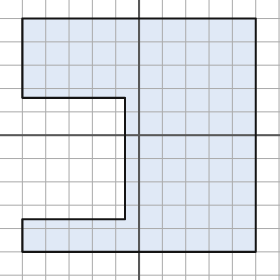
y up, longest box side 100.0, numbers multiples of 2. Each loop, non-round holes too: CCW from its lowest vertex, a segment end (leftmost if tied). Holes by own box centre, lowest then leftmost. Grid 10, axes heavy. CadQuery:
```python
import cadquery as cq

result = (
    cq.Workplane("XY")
    .moveTo(-50.0, -50.0)
    .lineTo(50.0, -50.0)
    .lineTo(50.0, 50.0)
    .lineTo(-50.0, 50.0)
    .lineTo(-50.0, 16.0)
    .lineTo(-6.0, 16.0)
    .lineTo(-6.0, -36.0)
    .lineTo(-50.0, -36.0)
    .close()
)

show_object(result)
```